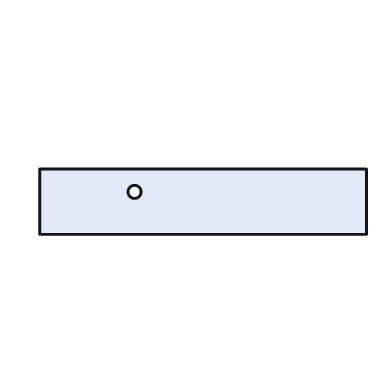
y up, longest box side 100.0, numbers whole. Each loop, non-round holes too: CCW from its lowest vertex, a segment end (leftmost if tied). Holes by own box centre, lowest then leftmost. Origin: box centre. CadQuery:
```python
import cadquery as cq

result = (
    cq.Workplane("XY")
    .moveTo(-50.0, -10.0)
    .lineTo(50.0, -10.0)
    .lineTo(50.0, 10.0)
    .lineTo(-50.0, 10.0)
    .close()
    .moveTo(-21.0, 3.0)
    .circle(2.0)
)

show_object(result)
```